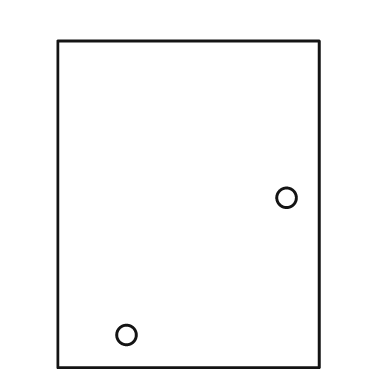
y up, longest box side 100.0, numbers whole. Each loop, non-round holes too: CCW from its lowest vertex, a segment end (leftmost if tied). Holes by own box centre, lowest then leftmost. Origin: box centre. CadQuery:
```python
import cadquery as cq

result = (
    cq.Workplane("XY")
    .moveTo(-40.0, -50.0)
    .lineTo(40.0, -50.0)
    .lineTo(40.0, 50.0)
    .lineTo(-40.0, 50.0)
    .close()
    .moveTo(-19.0, -40.0)
    .circle(3.0)
    .moveTo(30.0, 2.0)
    .circle(3.0)
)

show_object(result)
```